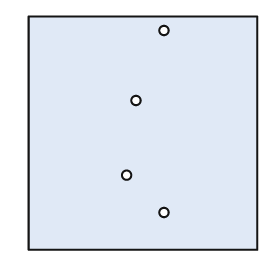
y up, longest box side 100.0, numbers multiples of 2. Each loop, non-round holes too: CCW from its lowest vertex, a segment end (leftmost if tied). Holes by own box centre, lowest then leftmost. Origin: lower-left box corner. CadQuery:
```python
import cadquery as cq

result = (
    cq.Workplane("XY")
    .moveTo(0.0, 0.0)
    .lineTo(98.0, 0.0)
    .lineTo(98.0, 100.0)
    .lineTo(0.0, 100.0)
    .close()
    .moveTo(58.0, 16.0)
    .circle(2.0)
    .moveTo(42.0, 32.0)
    .circle(2.0)
    .moveTo(46.0, 64.0)
    .circle(2.0)
    .moveTo(58.0, 94.0)
    .circle(2.0)
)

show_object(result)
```